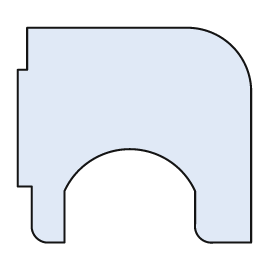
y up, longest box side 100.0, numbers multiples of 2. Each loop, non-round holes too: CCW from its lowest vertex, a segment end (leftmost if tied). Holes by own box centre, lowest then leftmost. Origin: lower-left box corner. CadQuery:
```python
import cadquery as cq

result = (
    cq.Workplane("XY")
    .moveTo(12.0, 0.0)
    .lineTo(20.0, 0.0)
    .lineTo(20.0, 22.0)
    .threePointArc((48.0, 40.0), (76.0, 22.0))
    .lineTo(76.0, 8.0)
    .threePointArc((78.0, 2.0), (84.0, 0.0))
    .lineTo(100.0, 0.0)
    .lineTo(100.0, 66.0)
    .threePointArc((92.0, 84.0), (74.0, 92.0))
    .lineTo(4.0, 92.0)
    .lineTo(4.0, 74.0)
    .lineTo(0.0, 74.0)
    .lineTo(0.0, 24.0)
    .lineTo(6.0, 24.0)
    .lineTo(6.0, 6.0)
    .threePointArc((8.0, 2.0), (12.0, 0.0))
    .close()
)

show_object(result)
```